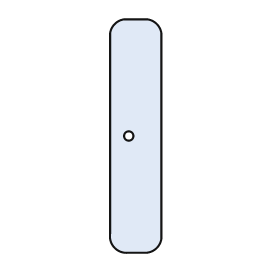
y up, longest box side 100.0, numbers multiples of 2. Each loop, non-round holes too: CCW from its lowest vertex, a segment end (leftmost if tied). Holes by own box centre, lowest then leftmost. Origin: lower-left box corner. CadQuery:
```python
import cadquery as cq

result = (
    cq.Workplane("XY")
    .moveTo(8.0, 0.0)
    .lineTo(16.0, 0.0)
    .threePointArc((20.0, 2.0), (22.0, 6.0))
    .lineTo(22.0, 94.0)
    .threePointArc((20.0, 98.0), (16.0, 100.0))
    .lineTo(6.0, 100.0)
    .threePointArc((2.0, 98.0), (0.0, 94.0))
    .lineTo(0.0, 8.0)
    .threePointArc((2.0, 2.0), (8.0, 0.0))
    .close()
    .moveTo(8.0, 50.0)
    .circle(2.0)
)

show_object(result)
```